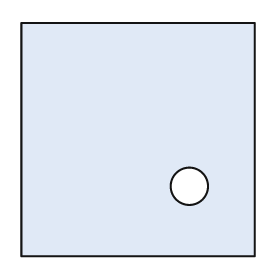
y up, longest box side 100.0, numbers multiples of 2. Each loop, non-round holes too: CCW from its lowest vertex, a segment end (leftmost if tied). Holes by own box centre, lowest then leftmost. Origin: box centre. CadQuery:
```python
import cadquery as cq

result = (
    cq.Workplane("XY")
    .moveTo(-50.0, -50.0)
    .lineTo(50.0, -50.0)
    .lineTo(50.0, 50.0)
    .lineTo(-50.0, 50.0)
    .close()
    .moveTo(22.0, -20.0)
    .circle(8.0)
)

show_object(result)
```